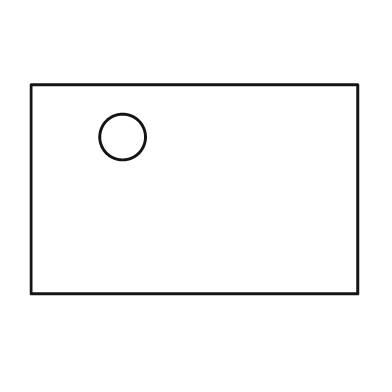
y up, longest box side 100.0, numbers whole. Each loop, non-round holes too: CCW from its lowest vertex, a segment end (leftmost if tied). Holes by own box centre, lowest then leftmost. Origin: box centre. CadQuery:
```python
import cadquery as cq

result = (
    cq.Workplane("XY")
    .moveTo(-50.0, -32.0)
    .lineTo(50.0, -32.0)
    .lineTo(50.0, 32.0)
    .lineTo(-50.0, 32.0)
    .close()
    .moveTo(-22.0, 16.0)
    .circle(7.0)
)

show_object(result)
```